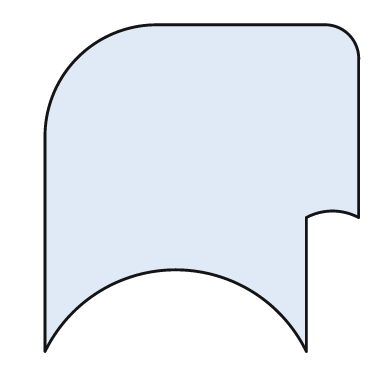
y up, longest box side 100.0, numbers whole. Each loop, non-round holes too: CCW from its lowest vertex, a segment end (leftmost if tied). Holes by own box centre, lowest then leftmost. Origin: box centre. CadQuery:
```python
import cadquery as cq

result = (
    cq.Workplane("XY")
    .moveTo(-48.0, -50.0)
    .threePointArc((-8.0, -25.0), (32.0, -50.0))
    .lineTo(32.0, -9.0)
    .threePointArc((40.0, -7.0), (48.0, -9.0))
    .lineTo(48.0, 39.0)
    .threePointArc((45.0, 47.0), (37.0, 50.0))
    .lineTo(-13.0, 50.0)
    .threePointArc((-38.0, 40.0), (-48.0, 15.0))
    .close()
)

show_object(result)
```